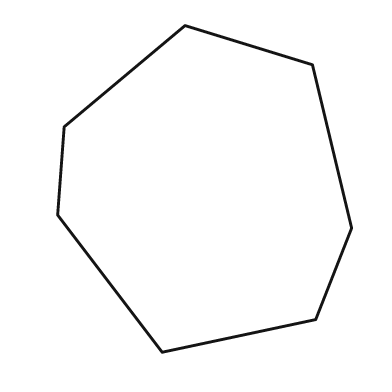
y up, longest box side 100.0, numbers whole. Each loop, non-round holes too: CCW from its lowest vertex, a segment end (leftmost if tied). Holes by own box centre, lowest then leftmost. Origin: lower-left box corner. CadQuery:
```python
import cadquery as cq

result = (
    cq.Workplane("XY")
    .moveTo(32.0, 0.0)
    .lineTo(79.0, 10.0)
    .lineTo(90.0, 38.0)
    .lineTo(78.0, 88.0)
    .lineTo(39.0, 100.0)
    .lineTo(2.0, 69.0)
    .lineTo(0.0, 42.0)
    .close()
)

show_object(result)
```